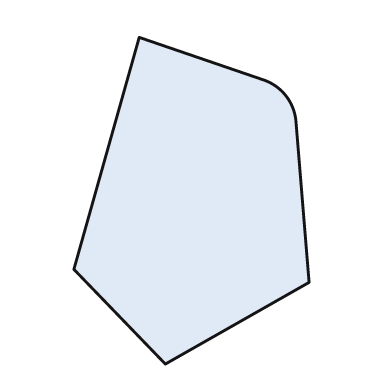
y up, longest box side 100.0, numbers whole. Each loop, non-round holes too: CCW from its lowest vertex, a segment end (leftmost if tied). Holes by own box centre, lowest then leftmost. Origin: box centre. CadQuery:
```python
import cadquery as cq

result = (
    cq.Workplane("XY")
    .moveTo(-8.0, -50.0)
    .lineTo(36.0, -25.0)
    .lineTo(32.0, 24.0)
    .threePointArc((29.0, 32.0), (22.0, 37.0))
    .lineTo(-16.0, 50.0)
    .lineTo(-36.0, -21.0)
    .close()
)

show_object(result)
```